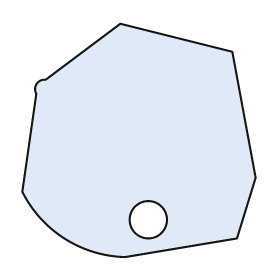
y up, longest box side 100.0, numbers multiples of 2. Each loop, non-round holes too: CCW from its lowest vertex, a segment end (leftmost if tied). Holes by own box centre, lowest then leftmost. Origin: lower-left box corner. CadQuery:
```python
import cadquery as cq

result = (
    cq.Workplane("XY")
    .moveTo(44.0, 0.0)
    .lineTo(92.0, 8.0)
    .lineTo(100.0, 34.0)
    .lineTo(90.0, 88.0)
    .lineTo(42.0, 100.0)
    .lineTo(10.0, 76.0)
    .threePointArc((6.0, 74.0), (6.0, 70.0))
    .lineTo(0.0, 28.0)
    .threePointArc((18.0, 8.0), (44.0, 0.0))
    .close()
    .moveTo(54.0, 16.0)
    .circle(8.0)
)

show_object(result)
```